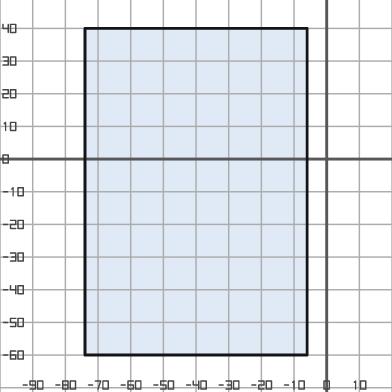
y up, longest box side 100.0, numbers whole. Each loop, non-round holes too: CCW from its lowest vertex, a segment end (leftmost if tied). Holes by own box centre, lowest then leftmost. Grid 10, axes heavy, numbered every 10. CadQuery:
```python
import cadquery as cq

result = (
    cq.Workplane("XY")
    .moveTo(-74.0, -60.0)
    .lineTo(-6.0, -60.0)
    .lineTo(-6.0, 40.0)
    .lineTo(-74.0, 40.0)
    .close()
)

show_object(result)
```